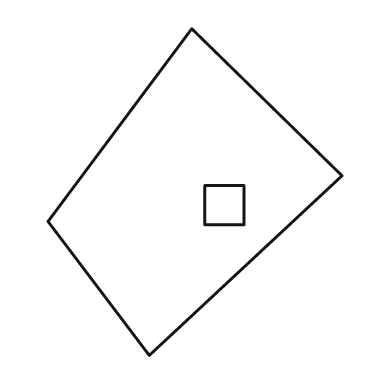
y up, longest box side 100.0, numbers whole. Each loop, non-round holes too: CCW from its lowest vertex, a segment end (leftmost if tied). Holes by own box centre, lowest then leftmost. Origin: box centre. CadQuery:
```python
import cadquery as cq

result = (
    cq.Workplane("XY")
    .moveTo(-14.0, -50.0)
    .lineTo(45.0, 5.0)
    .lineTo(-1.0, 50.0)
    .lineTo(-45.0, -9.0)
    .close()
    .moveTo(3.0, -10.0)
    .lineTo(15.0, -10.0)
    .lineTo(15.0, 2.0)
    .lineTo(3.0, 2.0)
    .close()
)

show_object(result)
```